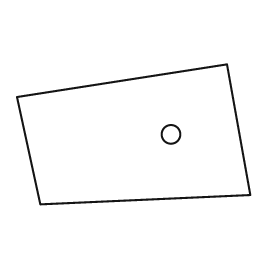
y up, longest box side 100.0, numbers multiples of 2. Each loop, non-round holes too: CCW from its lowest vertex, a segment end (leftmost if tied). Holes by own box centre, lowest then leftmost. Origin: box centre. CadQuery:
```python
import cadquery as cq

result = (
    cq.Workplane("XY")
    .moveTo(-40.0, -30.0)
    .lineTo(50.0, -26.0)
    .lineTo(40.0, 30.0)
    .lineTo(-50.0, 16.0)
    .close()
    .moveTo(16.0, 0.0)
    .circle(4.0)
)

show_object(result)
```